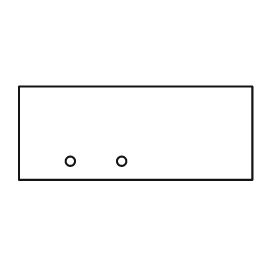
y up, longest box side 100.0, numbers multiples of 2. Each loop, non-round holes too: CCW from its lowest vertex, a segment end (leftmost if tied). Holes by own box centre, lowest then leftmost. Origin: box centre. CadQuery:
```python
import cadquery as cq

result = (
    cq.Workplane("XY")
    .moveTo(-50.0, -20.0)
    .lineTo(50.0, -20.0)
    .lineTo(50.0, 20.0)
    .lineTo(-50.0, 20.0)
    .close()
    .moveTo(-28.0, -12.0)
    .circle(2.0)
    .moveTo(-6.0, -12.0)
    .circle(2.0)
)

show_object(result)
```